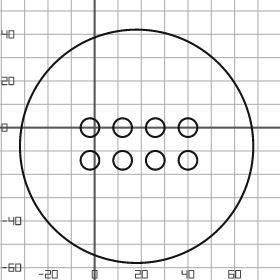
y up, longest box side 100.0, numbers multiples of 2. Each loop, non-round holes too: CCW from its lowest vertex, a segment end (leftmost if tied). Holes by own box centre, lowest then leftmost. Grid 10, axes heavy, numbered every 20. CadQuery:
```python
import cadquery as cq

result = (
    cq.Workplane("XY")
    .moveTo(18.0, -8.0)
    .circle(50.0)
    .moveTo(-2.0, -14.0)
    .circle(4.0)
    .moveTo(12.0, -14.0)
    .circle(4.0)
    .moveTo(26.0, -14.0)
    .circle(4.0)
    .moveTo(40.0, -14.0)
    .circle(4.0)
    .moveTo(-2.0, 0.0)
    .circle(4.0)
    .moveTo(12.0, 0.0)
    .circle(4.0)
    .moveTo(26.0, 0.0)
    .circle(4.0)
    .moveTo(40.0, 0.0)
    .circle(4.0)
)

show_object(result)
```